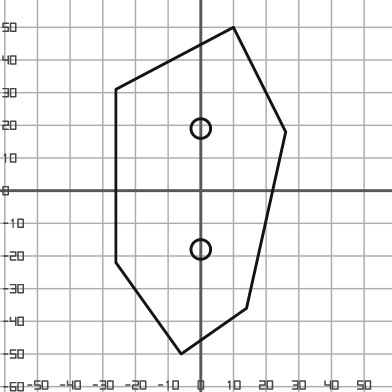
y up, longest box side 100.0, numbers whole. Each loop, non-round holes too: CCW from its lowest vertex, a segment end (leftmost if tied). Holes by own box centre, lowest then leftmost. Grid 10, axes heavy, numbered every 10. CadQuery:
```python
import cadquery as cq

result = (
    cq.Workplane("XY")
    .moveTo(-6.0, -50.0)
    .lineTo(14.0, -36.0)
    .lineTo(26.0, 18.0)
    .lineTo(10.0, 50.0)
    .lineTo(-26.0, 31.0)
    .lineTo(-26.0, -22.0)
    .close()
    .moveTo(0.0, -18.0)
    .circle(3.0)
    .moveTo(0.0, 19.0)
    .circle(3.0)
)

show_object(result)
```